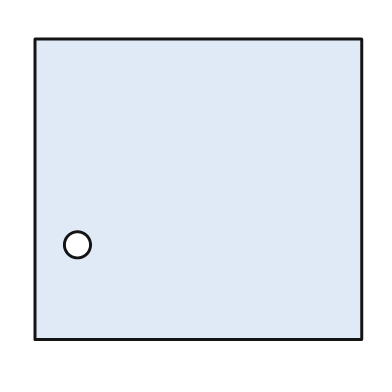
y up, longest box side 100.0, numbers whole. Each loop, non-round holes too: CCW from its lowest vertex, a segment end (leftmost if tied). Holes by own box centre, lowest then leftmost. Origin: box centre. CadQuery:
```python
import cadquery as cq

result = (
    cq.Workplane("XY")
    .moveTo(-50.0, -46.0)
    .lineTo(50.0, -46.0)
    .lineTo(50.0, 46.0)
    .lineTo(-50.0, 46.0)
    .close()
    .moveTo(-37.0, -17.0)
    .circle(4.0)
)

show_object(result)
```